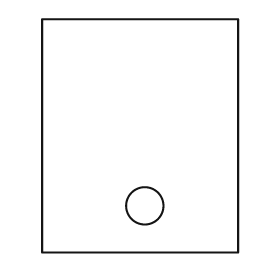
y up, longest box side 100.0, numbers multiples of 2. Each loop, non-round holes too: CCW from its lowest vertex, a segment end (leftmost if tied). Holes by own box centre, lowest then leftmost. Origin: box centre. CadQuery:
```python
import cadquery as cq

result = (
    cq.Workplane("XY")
    .moveTo(-42.0, -50.0)
    .lineTo(42.0, -50.0)
    .lineTo(42.0, 50.0)
    .lineTo(-42.0, 50.0)
    .close()
    .moveTo(2.0, -30.0)
    .circle(8.0)
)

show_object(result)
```